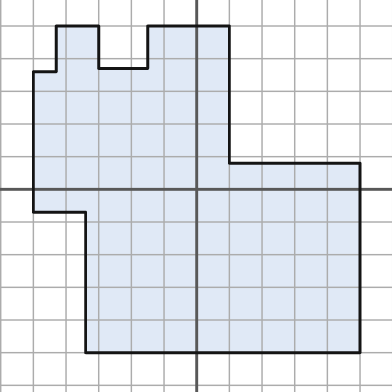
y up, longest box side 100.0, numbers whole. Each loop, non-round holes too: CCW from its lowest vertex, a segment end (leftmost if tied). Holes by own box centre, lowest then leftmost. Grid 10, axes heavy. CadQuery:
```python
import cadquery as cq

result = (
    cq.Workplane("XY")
    .moveTo(-34.0, -50.0)
    .lineTo(50.0, -50.0)
    .lineTo(50.0, 8.0)
    .lineTo(10.0, 8.0)
    .lineTo(10.0, 50.0)
    .lineTo(-15.0, 50.0)
    .lineTo(-15.0, 37.0)
    .lineTo(-30.0, 37.0)
    .lineTo(-30.0, 50.0)
    .lineTo(-43.0, 50.0)
    .lineTo(-43.0, 36.0)
    .lineTo(-50.0, 36.0)
    .lineTo(-50.0, -7.0)
    .lineTo(-34.0, -7.0)
    .close()
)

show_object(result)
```